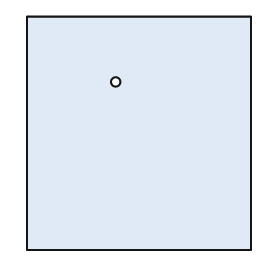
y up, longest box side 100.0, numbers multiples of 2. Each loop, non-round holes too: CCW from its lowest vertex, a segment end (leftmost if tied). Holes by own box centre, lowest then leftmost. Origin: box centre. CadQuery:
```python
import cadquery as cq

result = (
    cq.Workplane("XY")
    .moveTo(-48.0, -50.0)
    .lineTo(48.0, -50.0)
    .lineTo(48.0, 50.0)
    .lineTo(-48.0, 50.0)
    .close()
    .moveTo(-10.0, 22.0)
    .circle(2.0)
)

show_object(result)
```